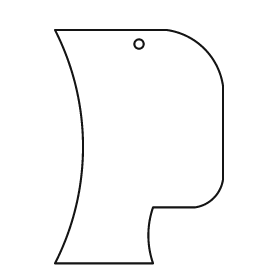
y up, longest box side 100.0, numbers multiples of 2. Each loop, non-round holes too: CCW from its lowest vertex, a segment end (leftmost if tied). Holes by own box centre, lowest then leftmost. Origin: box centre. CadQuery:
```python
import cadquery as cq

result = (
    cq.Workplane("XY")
    .moveTo(-36.0, -50.0)
    .lineTo(6.0, -50.0)
    .threePointArc((4.0, -38.0), (6.0, -26.0))
    .lineTo(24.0, -26.0)
    .threePointArc((32.0, -22.0), (36.0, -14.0))
    .lineTo(36.0, 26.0)
    .threePointArc((28.0, 42.0), (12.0, 50.0))
    .lineTo(-36.0, 50.0)
    .threePointArc((-24.0, 0.0), (-36.0, -50.0))
    .close()
    .moveTo(0.0, 44.0)
    .circle(2.0)
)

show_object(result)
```